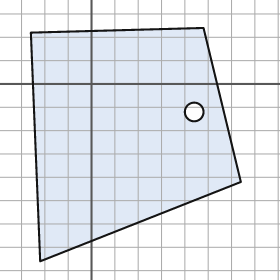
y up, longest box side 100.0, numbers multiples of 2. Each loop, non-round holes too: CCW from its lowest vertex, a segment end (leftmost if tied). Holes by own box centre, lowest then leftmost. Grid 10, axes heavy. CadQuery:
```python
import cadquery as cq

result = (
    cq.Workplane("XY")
    .moveTo(-22.0, -76.0)
    .lineTo(64.0, -42.0)
    .lineTo(48.0, 24.0)
    .lineTo(-26.0, 22.0)
    .close()
    .moveTo(44.0, -12.0)
    .circle(4.0)
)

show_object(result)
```